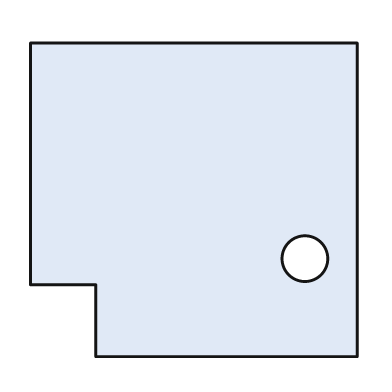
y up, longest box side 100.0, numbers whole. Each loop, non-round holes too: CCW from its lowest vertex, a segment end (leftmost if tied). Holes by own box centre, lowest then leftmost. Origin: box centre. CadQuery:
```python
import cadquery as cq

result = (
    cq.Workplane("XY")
    .moveTo(-30.0, -48.0)
    .lineTo(50.0, -48.0)
    .lineTo(50.0, 48.0)
    .lineTo(-50.0, 48.0)
    .lineTo(-50.0, -26.0)
    .lineTo(-30.0, -26.0)
    .close()
    .moveTo(34.0, -18.0)
    .circle(7.0)
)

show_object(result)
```